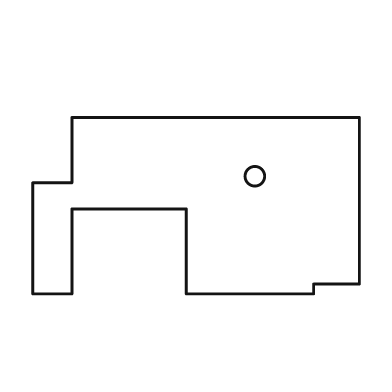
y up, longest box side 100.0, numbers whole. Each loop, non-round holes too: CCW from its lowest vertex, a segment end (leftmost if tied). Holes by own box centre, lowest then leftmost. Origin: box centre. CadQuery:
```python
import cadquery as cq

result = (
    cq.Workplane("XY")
    .moveTo(-50.0, -27.0)
    .lineTo(-38.0, -27.0)
    .lineTo(-38.0, -1.0)
    .lineTo(-3.0, -1.0)
    .lineTo(-3.0, -27.0)
    .lineTo(36.0, -27.0)
    .lineTo(36.0, -24.0)
    .lineTo(50.0, -24.0)
    .lineTo(50.0, 27.0)
    .lineTo(-38.0, 27.0)
    .lineTo(-38.0, 7.0)
    .lineTo(-50.0, 7.0)
    .close()
    .moveTo(18.0, 9.0)
    .circle(3.0)
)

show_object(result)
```